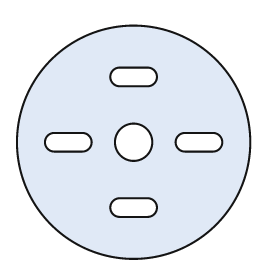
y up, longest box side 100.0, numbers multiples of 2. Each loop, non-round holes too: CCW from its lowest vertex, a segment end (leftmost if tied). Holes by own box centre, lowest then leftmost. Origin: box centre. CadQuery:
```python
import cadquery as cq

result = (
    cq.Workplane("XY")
    .moveTo(0.0, 0.0)
    .circle(50.0)
    .moveTo(-6.0, -32.0)
    .lineTo(6.0, -32.0)
    .threePointArc((10.0, -28.0), (6.0, -24.0))
    .lineTo(-6.0, -24.0)
    .threePointArc((-10.0, -28.0), (-6.0, -32.0))
    .close()
    .moveTo(-34.0, -4.0)
    .lineTo(-22.0, -4.0)
    .threePointArc((-18.0, 0.0), (-22.0, 4.0))
    .lineTo(-34.0, 4.0)
    .threePointArc((-38.0, 0.0), (-34.0, -4.0))
    .close()
    .moveTo(0.0, 0.0)
    .circle(8.0)
    .moveTo(22.0, -4.0)
    .lineTo(34.0, -4.0)
    .threePointArc((38.0, 0.0), (34.0, 4.0))
    .lineTo(22.0, 4.0)
    .threePointArc((18.0, 0.0), (22.0, -4.0))
    .close()
    .moveTo(-6.0, 24.0)
    .lineTo(6.0, 24.0)
    .threePointArc((10.0, 28.0), (6.0, 32.0))
    .lineTo(-6.0, 32.0)
    .threePointArc((-10.0, 28.0), (-6.0, 24.0))
    .close()
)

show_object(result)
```